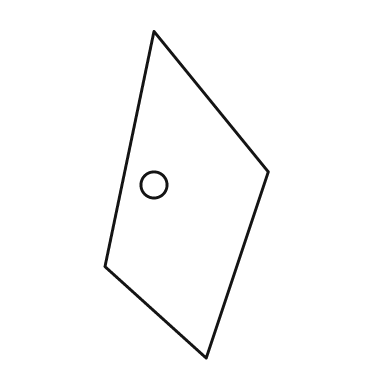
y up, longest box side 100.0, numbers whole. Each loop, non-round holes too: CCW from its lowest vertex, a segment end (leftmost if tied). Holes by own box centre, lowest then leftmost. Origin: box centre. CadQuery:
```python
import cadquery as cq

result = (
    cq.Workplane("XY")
    .moveTo(6.0, -50.0)
    .lineTo(25.0, 7.0)
    .lineTo(-10.0, 50.0)
    .lineTo(-25.0, -22.0)
    .close()
    .moveTo(-10.0, 3.0)
    .circle(4.0)
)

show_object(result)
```